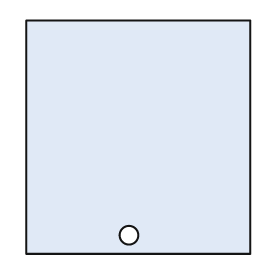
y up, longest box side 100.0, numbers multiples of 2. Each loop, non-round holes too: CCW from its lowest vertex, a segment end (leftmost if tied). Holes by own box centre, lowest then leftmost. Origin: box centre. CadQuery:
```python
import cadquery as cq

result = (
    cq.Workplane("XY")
    .moveTo(-48.0, -50.0)
    .lineTo(48.0, -50.0)
    .lineTo(48.0, 50.0)
    .lineTo(-48.0, 50.0)
    .close()
    .moveTo(-4.0, -42.0)
    .circle(4.0)
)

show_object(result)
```